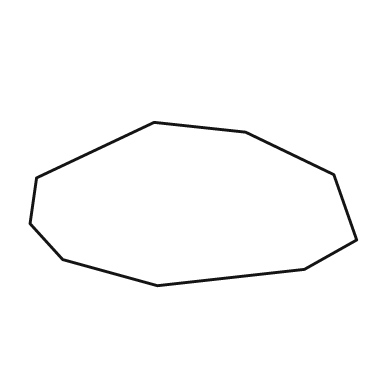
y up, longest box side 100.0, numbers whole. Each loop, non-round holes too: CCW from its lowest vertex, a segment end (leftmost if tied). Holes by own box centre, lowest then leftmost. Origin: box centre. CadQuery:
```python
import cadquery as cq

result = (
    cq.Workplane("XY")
    .moveTo(-11.0, -25.0)
    .lineTo(34.0, -20.0)
    .lineTo(50.0, -11.0)
    .lineTo(43.0, 9.0)
    .lineTo(16.0, 22.0)
    .lineTo(-12.0, 25.0)
    .lineTo(-48.0, 8.0)
    .lineTo(-50.0, -6.0)
    .lineTo(-40.0, -17.0)
    .close()
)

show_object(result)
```